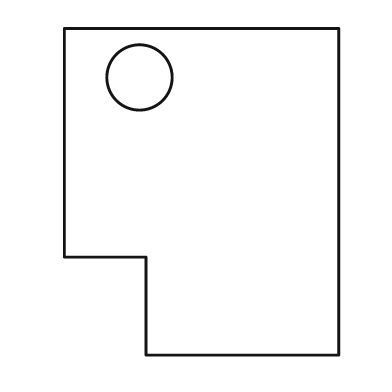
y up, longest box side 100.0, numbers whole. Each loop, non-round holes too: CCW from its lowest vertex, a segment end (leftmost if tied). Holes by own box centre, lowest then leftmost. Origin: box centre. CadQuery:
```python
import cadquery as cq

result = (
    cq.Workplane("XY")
    .moveTo(-17.0, -50.0)
    .lineTo(42.0, -50.0)
    .lineTo(42.0, 50.0)
    .lineTo(-42.0, 50.0)
    .lineTo(-42.0, -20.0)
    .lineTo(-17.0, -20.0)
    .close()
    .moveTo(-19.0, 35.0)
    .circle(10.0)
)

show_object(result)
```